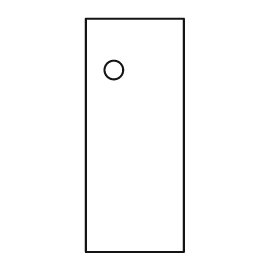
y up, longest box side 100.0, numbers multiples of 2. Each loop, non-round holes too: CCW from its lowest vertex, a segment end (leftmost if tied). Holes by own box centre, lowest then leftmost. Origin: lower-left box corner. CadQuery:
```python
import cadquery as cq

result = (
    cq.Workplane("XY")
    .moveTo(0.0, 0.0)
    .lineTo(42.0, 0.0)
    .lineTo(42.0, 100.0)
    .lineTo(0.0, 100.0)
    .close()
    .moveTo(12.0, 78.0)
    .circle(4.0)
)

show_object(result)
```